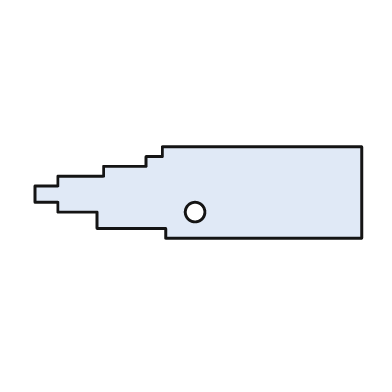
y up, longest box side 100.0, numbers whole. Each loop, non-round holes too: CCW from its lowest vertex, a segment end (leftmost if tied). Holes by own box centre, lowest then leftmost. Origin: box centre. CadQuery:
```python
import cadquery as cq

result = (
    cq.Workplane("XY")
    .moveTo(-10.0, -14.0)
    .lineTo(50.0, -14.0)
    .lineTo(50.0, 14.0)
    .lineTo(-11.0, 14.0)
    .lineTo(-11.0, 11.0)
    .lineTo(-16.0, 11.0)
    .lineTo(-16.0, 8.0)
    .lineTo(-29.0, 8.0)
    .lineTo(-29.0, 5.0)
    .lineTo(-43.0, 5.0)
    .lineTo(-43.0, 2.0)
    .lineTo(-50.0, 2.0)
    .lineTo(-50.0, -3.0)
    .lineTo(-43.0, -3.0)
    .lineTo(-43.0, -6.0)
    .lineTo(-31.0, -6.0)
    .lineTo(-31.0, -11.0)
    .lineTo(-10.0, -11.0)
    .close()
    .moveTo(-1.0, -6.0)
    .circle(3.0)
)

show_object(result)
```